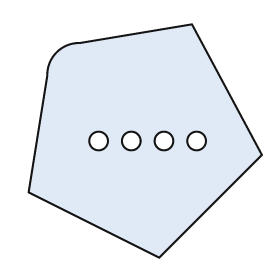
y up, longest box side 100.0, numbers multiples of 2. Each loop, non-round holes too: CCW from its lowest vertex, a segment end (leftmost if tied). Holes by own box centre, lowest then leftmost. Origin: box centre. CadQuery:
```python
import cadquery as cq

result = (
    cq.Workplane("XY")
    .moveTo(6.0, -50.0)
    .lineTo(50.0, -6.0)
    .lineTo(20.0, 50.0)
    .lineTo(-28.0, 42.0)
    .threePointArc((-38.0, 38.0), (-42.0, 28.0))
    .lineTo(-50.0, -22.0)
    .close()
    .moveTo(-20.0, 0.0)
    .circle(4.0)
    .moveTo(-6.0, 0.0)
    .circle(4.0)
    .moveTo(8.0, 0.0)
    .circle(4.0)
    .moveTo(22.0, 0.0)
    .circle(4.0)
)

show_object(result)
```